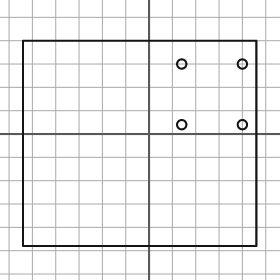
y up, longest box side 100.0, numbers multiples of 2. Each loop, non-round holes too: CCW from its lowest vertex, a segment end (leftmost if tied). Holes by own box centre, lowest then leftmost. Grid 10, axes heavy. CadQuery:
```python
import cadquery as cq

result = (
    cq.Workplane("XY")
    .moveTo(-54.0, -48.0)
    .lineTo(46.0, -48.0)
    .lineTo(46.0, 40.0)
    .lineTo(-54.0, 40.0)
    .close()
    .moveTo(14.0, 4.0)
    .circle(2.0)
    .moveTo(40.0, 4.0)
    .circle(2.0)
    .moveTo(14.0, 30.0)
    .circle(2.0)
    .moveTo(40.0, 30.0)
    .circle(2.0)
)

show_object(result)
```